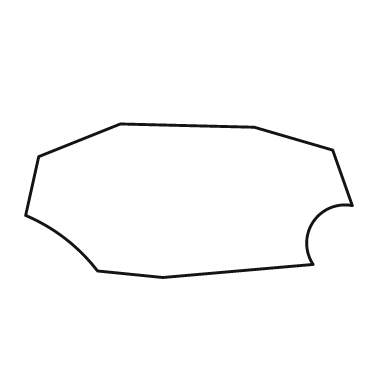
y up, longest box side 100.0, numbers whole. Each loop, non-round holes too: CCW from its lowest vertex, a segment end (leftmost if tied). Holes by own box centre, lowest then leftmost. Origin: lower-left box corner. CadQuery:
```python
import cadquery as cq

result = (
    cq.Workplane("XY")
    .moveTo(42.0, 0.0)
    .lineTo(88.0, 4.0)
    .threePointArc((88.0, 17.0), (100.0, 22.0))
    .lineTo(94.0, 39.0)
    .lineTo(70.0, 46.0)
    .lineTo(29.0, 47.0)
    .lineTo(4.0, 37.0)
    .lineTo(0.0, 19.0)
    .threePointArc((12.0, 12.0), (22.0, 2.0))
    .close()
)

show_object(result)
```